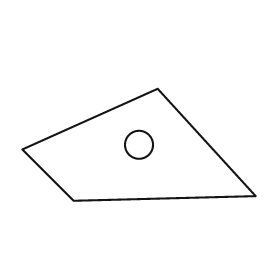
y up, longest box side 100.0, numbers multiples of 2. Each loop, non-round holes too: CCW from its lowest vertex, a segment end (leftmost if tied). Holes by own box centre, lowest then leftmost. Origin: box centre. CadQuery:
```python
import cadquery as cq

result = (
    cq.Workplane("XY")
    .moveTo(-28.0, -24.0)
    .lineTo(50.0, -22.0)
    .lineTo(8.0, 24.0)
    .lineTo(-50.0, -2.0)
    .close()
    .moveTo(0.0, 0.0)
    .circle(6.0)
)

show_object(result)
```